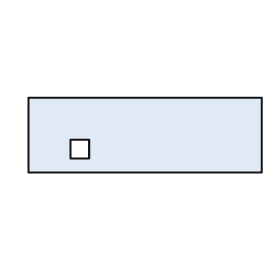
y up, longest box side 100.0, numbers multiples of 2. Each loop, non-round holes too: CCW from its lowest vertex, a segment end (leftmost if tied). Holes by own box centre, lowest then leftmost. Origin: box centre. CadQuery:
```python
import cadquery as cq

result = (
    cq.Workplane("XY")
    .moveTo(-50.0, -16.0)
    .lineTo(50.0, -16.0)
    .lineTo(50.0, 16.0)
    .lineTo(-50.0, 16.0)
    .close()
    .moveTo(-32.0, -10.0)
    .lineTo(-24.0, -10.0)
    .lineTo(-24.0, -2.0)
    .lineTo(-32.0, -2.0)
    .close()
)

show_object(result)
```